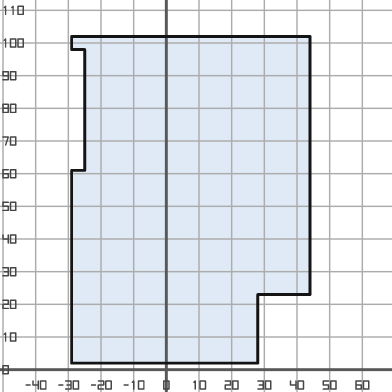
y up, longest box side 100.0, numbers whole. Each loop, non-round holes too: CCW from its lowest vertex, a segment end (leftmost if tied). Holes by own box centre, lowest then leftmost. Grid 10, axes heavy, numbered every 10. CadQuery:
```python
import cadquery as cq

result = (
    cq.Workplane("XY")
    .moveTo(-29.0, 2.0)
    .lineTo(28.0, 2.0)
    .lineTo(28.0, 23.0)
    .lineTo(44.0, 23.0)
    .lineTo(44.0, 102.0)
    .lineTo(-29.0, 102.0)
    .lineTo(-29.0, 98.0)
    .lineTo(-25.0, 98.0)
    .lineTo(-25.0, 61.0)
    .lineTo(-29.0, 61.0)
    .close()
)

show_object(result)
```